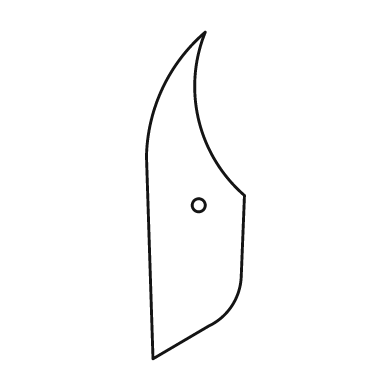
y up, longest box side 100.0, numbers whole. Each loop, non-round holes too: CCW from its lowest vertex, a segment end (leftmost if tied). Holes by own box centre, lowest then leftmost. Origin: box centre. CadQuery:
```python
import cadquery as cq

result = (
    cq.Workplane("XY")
    .moveTo(-13.0, -50.0)
    .lineTo(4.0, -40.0)
    .threePointArc((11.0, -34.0), (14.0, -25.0))
    .lineTo(15.0, 0.0)
    .threePointArc((1.0, 23.0), (3.0, 50.0))
    .threePointArc((-10.0, 33.0), (-15.0, 12.0))
    .close()
    .moveTo(1.0, -3.0)
    .circle(2.0)
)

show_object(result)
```